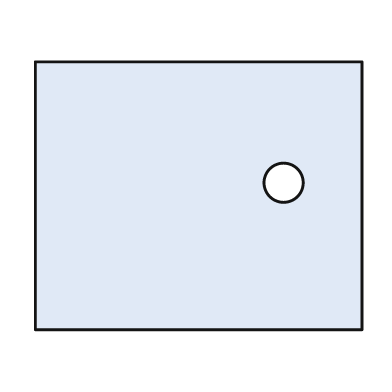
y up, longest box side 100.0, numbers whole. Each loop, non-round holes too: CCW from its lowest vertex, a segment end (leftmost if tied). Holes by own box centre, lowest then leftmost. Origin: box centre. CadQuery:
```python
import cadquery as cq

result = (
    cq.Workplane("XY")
    .moveTo(-50.0, -41.0)
    .lineTo(50.0, -41.0)
    .lineTo(50.0, 41.0)
    .lineTo(-50.0, 41.0)
    .close()
    .moveTo(26.0, 4.0)
    .circle(6.0)
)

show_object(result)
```